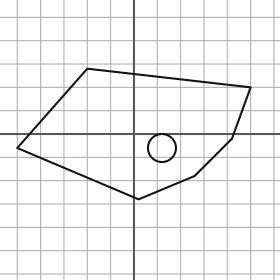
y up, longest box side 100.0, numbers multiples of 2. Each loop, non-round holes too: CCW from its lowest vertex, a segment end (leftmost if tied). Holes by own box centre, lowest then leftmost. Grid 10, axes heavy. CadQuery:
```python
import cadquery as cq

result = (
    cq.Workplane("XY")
    .moveTo(2.0, -28.0)
    .lineTo(26.0, -18.0)
    .lineTo(42.0, -2.0)
    .lineTo(50.0, 20.0)
    .lineTo(-20.0, 28.0)
    .lineTo(-50.0, -6.0)
    .close()
    .moveTo(12.0, -6.0)
    .circle(6.0)
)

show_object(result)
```